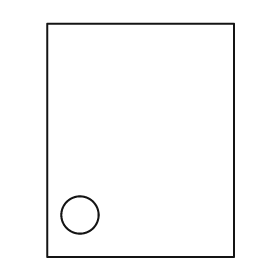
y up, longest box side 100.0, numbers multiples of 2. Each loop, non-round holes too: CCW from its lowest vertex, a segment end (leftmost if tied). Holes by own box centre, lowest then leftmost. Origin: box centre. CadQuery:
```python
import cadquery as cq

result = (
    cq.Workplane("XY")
    .moveTo(-40.0, -50.0)
    .lineTo(40.0, -50.0)
    .lineTo(40.0, 50.0)
    .lineTo(-40.0, 50.0)
    .close()
    .moveTo(-26.0, -32.0)
    .circle(8.0)
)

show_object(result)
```